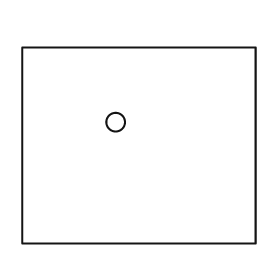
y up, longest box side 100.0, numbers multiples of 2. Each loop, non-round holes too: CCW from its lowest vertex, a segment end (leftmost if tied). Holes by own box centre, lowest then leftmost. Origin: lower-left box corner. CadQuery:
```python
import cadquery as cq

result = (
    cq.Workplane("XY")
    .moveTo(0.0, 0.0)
    .lineTo(100.0, 0.0)
    .lineTo(100.0, 84.0)
    .lineTo(0.0, 84.0)
    .close()
    .moveTo(40.0, 52.0)
    .circle(4.0)
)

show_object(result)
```